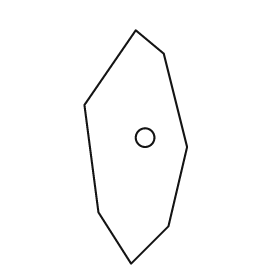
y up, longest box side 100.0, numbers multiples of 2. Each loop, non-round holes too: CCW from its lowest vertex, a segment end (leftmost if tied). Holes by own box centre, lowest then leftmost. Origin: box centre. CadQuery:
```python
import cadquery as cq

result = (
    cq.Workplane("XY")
    .moveTo(-2.0, -50.0)
    .lineTo(14.0, -34.0)
    .lineTo(22.0, 0.0)
    .lineTo(12.0, 40.0)
    .lineTo(0.0, 50.0)
    .lineTo(-22.0, 18.0)
    .lineTo(-16.0, -28.0)
    .close()
    .moveTo(4.0, 4.0)
    .circle(4.0)
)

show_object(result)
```